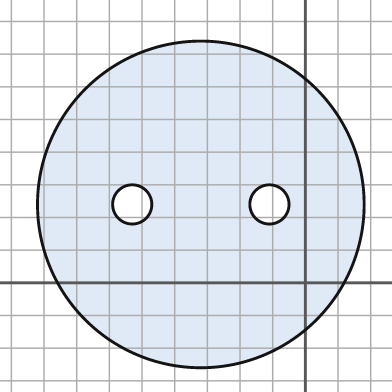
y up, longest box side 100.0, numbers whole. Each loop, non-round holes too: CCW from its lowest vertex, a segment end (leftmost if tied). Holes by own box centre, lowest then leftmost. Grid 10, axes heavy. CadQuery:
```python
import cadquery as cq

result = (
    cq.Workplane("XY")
    .moveTo(-32.0, 24.0)
    .circle(50.0)
    .moveTo(-53.0, 24.0)
    .circle(6.0)
    .moveTo(-11.0, 24.0)
    .circle(6.0)
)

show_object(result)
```